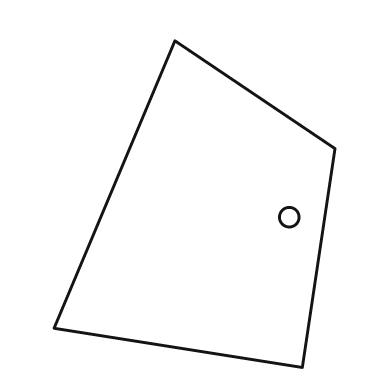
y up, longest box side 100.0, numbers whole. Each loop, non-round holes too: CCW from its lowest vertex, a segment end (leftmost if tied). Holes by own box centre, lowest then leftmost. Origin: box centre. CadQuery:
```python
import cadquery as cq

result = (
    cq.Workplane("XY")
    .moveTo(33.0, -50.0)
    .lineTo(43.0, 17.0)
    .lineTo(-6.0, 50.0)
    .lineTo(-43.0, -38.0)
    .close()
    .moveTo(29.0, -4.0)
    .circle(3.0)
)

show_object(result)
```